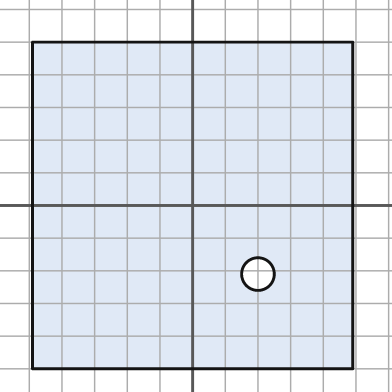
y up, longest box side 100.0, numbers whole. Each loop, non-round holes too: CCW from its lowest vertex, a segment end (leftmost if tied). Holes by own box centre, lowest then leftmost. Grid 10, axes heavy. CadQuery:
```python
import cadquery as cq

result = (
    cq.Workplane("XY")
    .moveTo(-49.0, -50.0)
    .lineTo(49.0, -50.0)
    .lineTo(49.0, 50.0)
    .lineTo(-49.0, 50.0)
    .close()
    .moveTo(20.0, -21.0)
    .circle(5.0)
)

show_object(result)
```